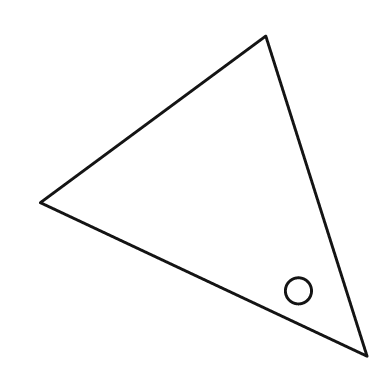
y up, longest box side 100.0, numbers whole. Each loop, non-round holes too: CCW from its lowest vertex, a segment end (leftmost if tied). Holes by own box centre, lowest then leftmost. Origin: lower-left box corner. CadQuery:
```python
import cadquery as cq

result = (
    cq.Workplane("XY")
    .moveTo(100.0, 0.0)
    .lineTo(69.0, 98.0)
    .lineTo(0.0, 47.0)
    .close()
    .moveTo(79.0, 20.0)
    .circle(4.0)
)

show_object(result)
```